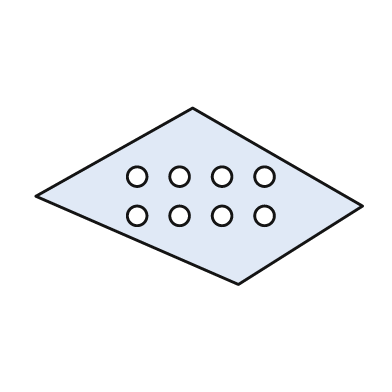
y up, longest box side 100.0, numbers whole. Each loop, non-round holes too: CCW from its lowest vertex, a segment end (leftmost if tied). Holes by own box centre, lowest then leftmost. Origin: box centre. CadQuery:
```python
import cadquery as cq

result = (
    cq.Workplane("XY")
    .moveTo(12.0, -27.0)
    .lineTo(50.0, -3.0)
    .lineTo(-2.0, 27.0)
    .lineTo(-50.0, 0.0)
    .close()
    .moveTo(-19.0, -6.0)
    .circle(3.0)
    .moveTo(-6.0, -6.0)
    .circle(3.0)
    .moveTo(7.0, -6.0)
    .circle(3.0)
    .moveTo(20.0, -6.0)
    .circle(3.0)
    .moveTo(-19.0, 6.0)
    .circle(3.0)
    .moveTo(-6.0, 6.0)
    .circle(3.0)
    .moveTo(7.0, 6.0)
    .circle(3.0)
    .moveTo(20.0, 6.0)
    .circle(3.0)
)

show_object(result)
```